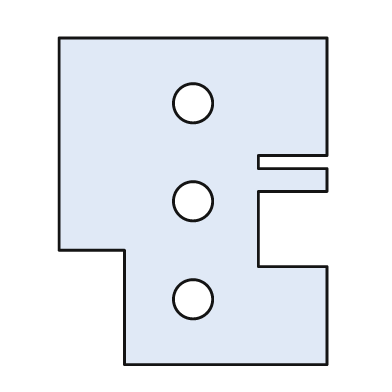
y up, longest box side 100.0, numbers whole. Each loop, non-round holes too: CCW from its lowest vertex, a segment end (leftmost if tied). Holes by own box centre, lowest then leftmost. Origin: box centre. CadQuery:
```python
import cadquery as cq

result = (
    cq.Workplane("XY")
    .moveTo(-21.0, -50.0)
    .lineTo(41.0, -50.0)
    .lineTo(41.0, -20.0)
    .lineTo(20.0, -20.0)
    .lineTo(20.0, 3.0)
    .lineTo(41.0, 3.0)
    .lineTo(41.0, 10.0)
    .lineTo(20.0, 10.0)
    .lineTo(20.0, 14.0)
    .lineTo(41.0, 14.0)
    .lineTo(41.0, 50.0)
    .lineTo(-41.0, 50.0)
    .lineTo(-41.0, -15.0)
    .lineTo(-21.0, -15.0)
    .close()
    .moveTo(0.0, -30.0)
    .circle(6.0)
    .moveTo(0.0, 0.0)
    .circle(6.0)
    .moveTo(0.0, 30.0)
    .circle(6.0)
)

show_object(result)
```